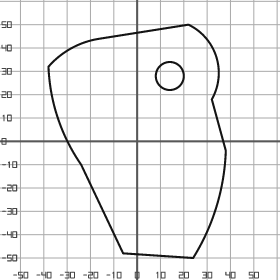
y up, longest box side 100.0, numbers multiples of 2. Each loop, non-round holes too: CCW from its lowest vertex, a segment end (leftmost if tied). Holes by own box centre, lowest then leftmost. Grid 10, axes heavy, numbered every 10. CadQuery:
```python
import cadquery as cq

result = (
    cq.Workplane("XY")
    .moveTo(24.0, -50.0)
    .threePointArc((34.0, -28.0), (38.0, -4.0))
    .lineTo(32.0, 18.0)
    .threePointArc((34.0, 36.0), (22.0, 50.0))
    .lineTo(-16.0, 44.0)
    .threePointArc((-28.0, 40.0), (-38.0, 32.0))
    .threePointArc((-34.0, 10.0), (-24.0, -10.0))
    .lineTo(-6.0, -48.0)
    .close()
    .moveTo(14.0, 28.0)
    .circle(6.0)
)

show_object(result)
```